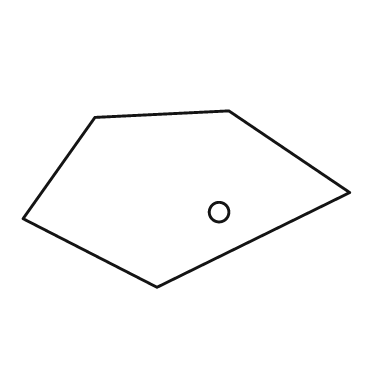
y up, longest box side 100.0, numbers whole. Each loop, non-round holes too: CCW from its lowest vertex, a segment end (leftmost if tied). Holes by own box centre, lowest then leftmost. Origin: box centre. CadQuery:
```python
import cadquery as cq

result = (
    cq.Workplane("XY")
    .moveTo(-9.0, -27.0)
    .lineTo(50.0, 2.0)
    .lineTo(13.0, 27.0)
    .lineTo(-28.0, 25.0)
    .lineTo(-50.0, -6.0)
    .close()
    .moveTo(10.0, -4.0)
    .circle(3.0)
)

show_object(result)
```